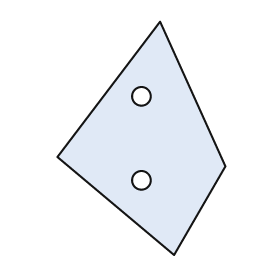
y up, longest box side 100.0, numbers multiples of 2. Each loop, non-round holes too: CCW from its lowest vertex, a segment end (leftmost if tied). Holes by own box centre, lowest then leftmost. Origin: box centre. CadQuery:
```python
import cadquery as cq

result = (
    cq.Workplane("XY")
    .moveTo(14.0, -50.0)
    .lineTo(36.0, -12.0)
    .lineTo(8.0, 50.0)
    .lineTo(-36.0, -8.0)
    .close()
    .moveTo(0.0, -18.0)
    .circle(4.0)
    .moveTo(0.0, 18.0)
    .circle(4.0)
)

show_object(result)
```